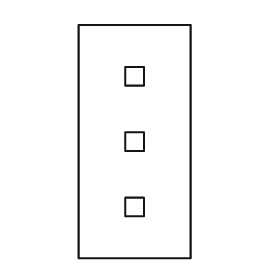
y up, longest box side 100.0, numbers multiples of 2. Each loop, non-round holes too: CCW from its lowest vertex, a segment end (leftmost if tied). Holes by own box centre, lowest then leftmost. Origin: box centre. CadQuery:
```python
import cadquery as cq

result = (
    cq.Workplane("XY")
    .moveTo(-24.0, -50.0)
    .lineTo(24.0, -50.0)
    .lineTo(24.0, 50.0)
    .lineTo(-24.0, 50.0)
    .close()
    .moveTo(-4.0, -32.0)
    .lineTo(4.0, -32.0)
    .lineTo(4.0, -24.0)
    .lineTo(-4.0, -24.0)
    .close()
    .moveTo(-4.0, -4.0)
    .lineTo(4.0, -4.0)
    .lineTo(4.0, 4.0)
    .lineTo(-4.0, 4.0)
    .close()
    .moveTo(-4.0, 24.0)
    .lineTo(4.0, 24.0)
    .lineTo(4.0, 32.0)
    .lineTo(-4.0, 32.0)
    .close()
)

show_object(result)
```